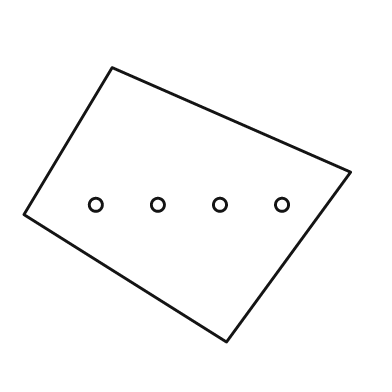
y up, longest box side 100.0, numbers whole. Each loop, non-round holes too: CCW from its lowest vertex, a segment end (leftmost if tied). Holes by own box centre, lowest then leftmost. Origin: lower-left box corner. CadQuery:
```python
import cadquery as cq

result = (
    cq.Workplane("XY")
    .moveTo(62.0, 0.0)
    .lineTo(100.0, 52.0)
    .lineTo(27.0, 84.0)
    .lineTo(0.0, 39.0)
    .close()
    .moveTo(22.0, 42.0)
    .circle(2.0)
    .moveTo(41.0, 42.0)
    .circle(2.0)
    .moveTo(60.0, 42.0)
    .circle(2.0)
    .moveTo(79.0, 42.0)
    .circle(2.0)
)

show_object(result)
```